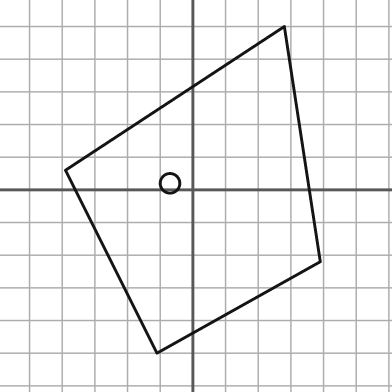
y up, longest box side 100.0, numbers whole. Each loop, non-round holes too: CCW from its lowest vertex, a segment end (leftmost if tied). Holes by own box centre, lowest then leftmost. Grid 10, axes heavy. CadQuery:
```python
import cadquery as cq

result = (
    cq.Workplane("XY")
    .moveTo(-11.0, -50.0)
    .lineTo(39.0, -22.0)
    .lineTo(28.0, 50.0)
    .lineTo(-39.0, 6.0)
    .close()
    .moveTo(-7.0, 2.0)
    .circle(3.0)
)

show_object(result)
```